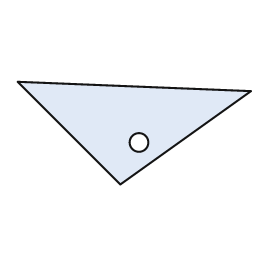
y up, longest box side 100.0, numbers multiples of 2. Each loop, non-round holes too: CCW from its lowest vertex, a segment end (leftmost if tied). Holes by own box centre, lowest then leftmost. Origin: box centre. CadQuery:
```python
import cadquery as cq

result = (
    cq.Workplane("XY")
    .moveTo(-6.0, -22.0)
    .lineTo(50.0, 18.0)
    .lineTo(-50.0, 22.0)
    .close()
    .moveTo(2.0, -4.0)
    .circle(4.0)
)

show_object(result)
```